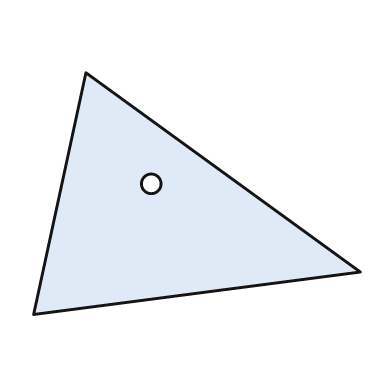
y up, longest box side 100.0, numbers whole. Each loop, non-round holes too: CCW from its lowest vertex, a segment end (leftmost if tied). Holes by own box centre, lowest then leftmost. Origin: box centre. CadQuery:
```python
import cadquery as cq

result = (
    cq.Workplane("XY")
    .moveTo(-50.0, -37.0)
    .lineTo(50.0, -24.0)
    .lineTo(-34.0, 37.0)
    .close()
    .moveTo(-14.0, 3.0)
    .circle(3.0)
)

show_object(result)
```